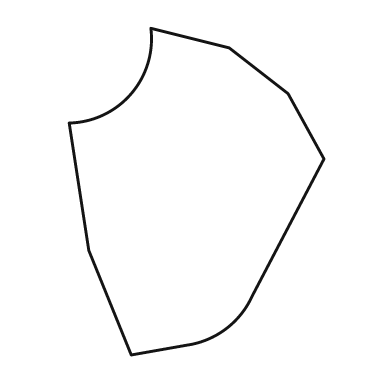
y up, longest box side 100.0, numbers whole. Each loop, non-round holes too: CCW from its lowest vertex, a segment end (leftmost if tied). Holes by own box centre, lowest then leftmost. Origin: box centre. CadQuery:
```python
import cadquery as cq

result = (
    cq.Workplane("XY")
    .moveTo(-20.0, -50.0)
    .lineTo(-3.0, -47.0)
    .threePointArc((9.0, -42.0), (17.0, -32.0))
    .lineTo(39.0, 10.0)
    .lineTo(28.0, 30.0)
    .lineTo(10.0, 44.0)
    .lineTo(-14.0, 50.0)
    .threePointArc((-20.0, 30.0), (-39.0, 21.0))
    .lineTo(-33.0, -18.0)
    .close()
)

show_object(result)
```